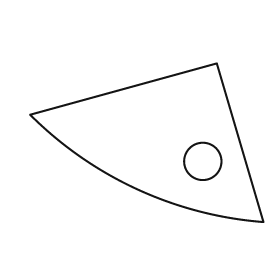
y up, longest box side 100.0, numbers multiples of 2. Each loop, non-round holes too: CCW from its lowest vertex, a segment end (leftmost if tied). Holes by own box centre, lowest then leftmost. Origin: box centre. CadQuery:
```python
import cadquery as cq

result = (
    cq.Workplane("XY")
    .moveTo(50.0, -34.0)
    .lineTo(30.0, 34.0)
    .lineTo(-50.0, 12.0)
    .threePointArc((-4.0, -20.0), (50.0, -34.0))
    .close()
    .moveTo(24.0, -8.0)
    .circle(8.0)
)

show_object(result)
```